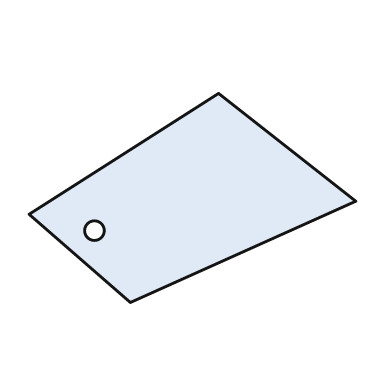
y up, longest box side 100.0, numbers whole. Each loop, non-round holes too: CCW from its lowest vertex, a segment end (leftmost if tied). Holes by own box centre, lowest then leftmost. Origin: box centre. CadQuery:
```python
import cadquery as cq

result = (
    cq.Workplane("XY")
    .moveTo(-19.0, -32.0)
    .lineTo(50.0, -1.0)
    .lineTo(8.0, 32.0)
    .lineTo(-50.0, -5.0)
    .close()
    .moveTo(-30.0, -10.0)
    .circle(3.0)
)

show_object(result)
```